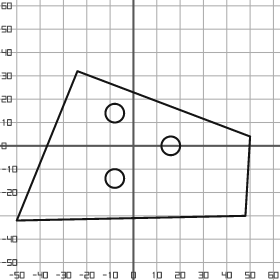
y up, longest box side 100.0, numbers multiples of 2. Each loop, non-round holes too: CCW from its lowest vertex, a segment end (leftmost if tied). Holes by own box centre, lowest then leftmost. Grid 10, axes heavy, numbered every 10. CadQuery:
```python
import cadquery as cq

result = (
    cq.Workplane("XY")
    .moveTo(-50.0, -32.0)
    .lineTo(48.0, -30.0)
    .lineTo(50.0, 4.0)
    .lineTo(-24.0, 32.0)
    .close()
    .moveTo(-8.0, -14.0)
    .circle(4.0)
    .moveTo(16.0, 0.0)
    .circle(4.0)
    .moveTo(-8.0, 14.0)
    .circle(4.0)
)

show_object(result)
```